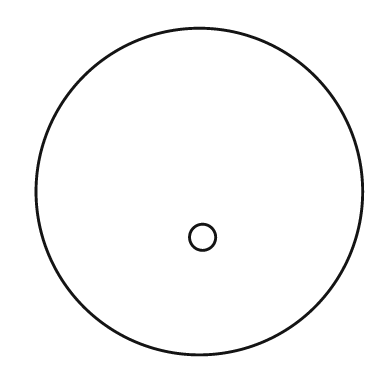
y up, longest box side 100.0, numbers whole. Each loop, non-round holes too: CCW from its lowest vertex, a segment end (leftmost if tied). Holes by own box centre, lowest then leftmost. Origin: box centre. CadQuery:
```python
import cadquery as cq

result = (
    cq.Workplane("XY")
    .moveTo(0.0, 0.0)
    .circle(50.0)
    .moveTo(1.0, -14.0)
    .circle(4.0)
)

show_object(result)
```